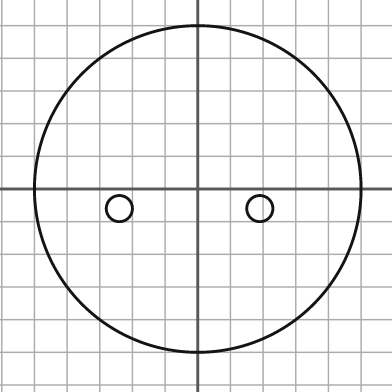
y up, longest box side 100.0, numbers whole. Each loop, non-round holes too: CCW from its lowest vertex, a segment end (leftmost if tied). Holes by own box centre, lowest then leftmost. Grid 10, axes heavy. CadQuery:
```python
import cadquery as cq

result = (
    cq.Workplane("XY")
    .moveTo(0.0, 0.0)
    .circle(50.0)
    .moveTo(-24.0, -6.0)
    .circle(4.0)
    .moveTo(19.0, -6.0)
    .circle(4.0)
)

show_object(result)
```